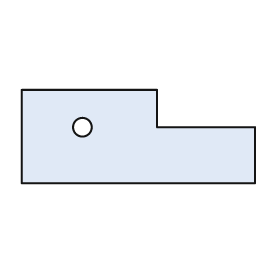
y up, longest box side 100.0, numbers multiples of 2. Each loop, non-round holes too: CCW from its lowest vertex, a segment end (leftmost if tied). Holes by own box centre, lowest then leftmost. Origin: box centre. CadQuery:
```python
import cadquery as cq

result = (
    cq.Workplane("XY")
    .moveTo(-50.0, -20.0)
    .lineTo(50.0, -20.0)
    .lineTo(50.0, 4.0)
    .lineTo(8.0, 4.0)
    .lineTo(8.0, 20.0)
    .lineTo(-50.0, 20.0)
    .close()
    .moveTo(-24.0, 4.0)
    .circle(4.0)
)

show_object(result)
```